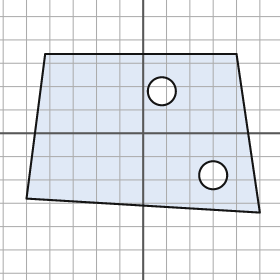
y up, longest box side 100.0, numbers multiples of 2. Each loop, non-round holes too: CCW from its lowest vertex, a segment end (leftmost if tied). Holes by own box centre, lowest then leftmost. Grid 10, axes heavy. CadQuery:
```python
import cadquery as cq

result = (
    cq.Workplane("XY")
    .moveTo(50.0, -34.0)
    .lineTo(40.0, 34.0)
    .lineTo(-42.0, 34.0)
    .lineTo(-50.0, -28.0)
    .close()
    .moveTo(30.0, -18.0)
    .circle(6.0)
    .moveTo(8.0, 18.0)
    .circle(6.0)
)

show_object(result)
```